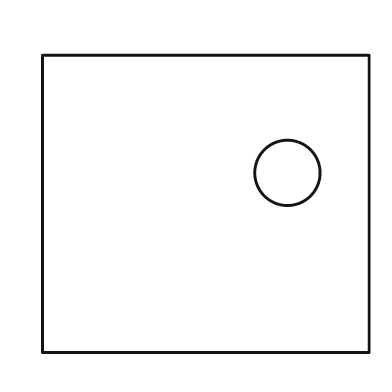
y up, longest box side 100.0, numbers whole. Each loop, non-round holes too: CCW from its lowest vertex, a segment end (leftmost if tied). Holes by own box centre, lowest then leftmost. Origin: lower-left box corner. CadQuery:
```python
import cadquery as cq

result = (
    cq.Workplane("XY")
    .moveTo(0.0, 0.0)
    .lineTo(100.0, 0.0)
    .lineTo(100.0, 91.0)
    .lineTo(0.0, 91.0)
    .close()
    .moveTo(75.0, 55.0)
    .circle(10.0)
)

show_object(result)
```